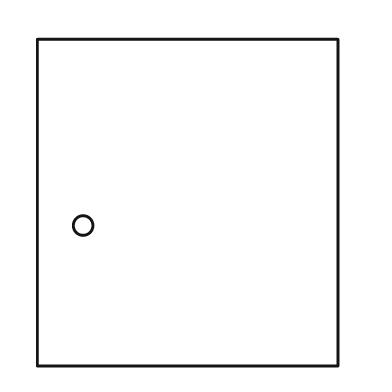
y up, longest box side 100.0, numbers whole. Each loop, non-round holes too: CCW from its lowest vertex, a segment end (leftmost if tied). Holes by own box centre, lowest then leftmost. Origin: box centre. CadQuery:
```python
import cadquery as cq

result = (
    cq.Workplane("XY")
    .moveTo(-46.0, -50.0)
    .lineTo(46.0, -50.0)
    .lineTo(46.0, 50.0)
    .lineTo(-46.0, 50.0)
    .close()
    .moveTo(-32.0, -7.0)
    .circle(3.0)
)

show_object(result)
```